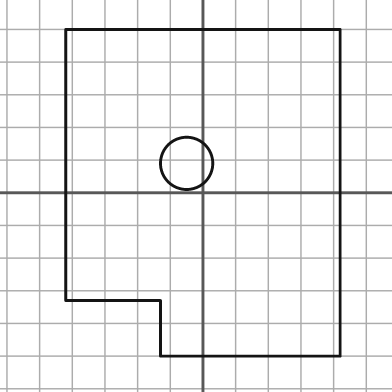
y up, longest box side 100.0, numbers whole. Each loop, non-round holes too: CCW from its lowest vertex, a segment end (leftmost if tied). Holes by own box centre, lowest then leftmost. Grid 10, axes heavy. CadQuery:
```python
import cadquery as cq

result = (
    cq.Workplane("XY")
    .moveTo(-13.0, -50.0)
    .lineTo(42.0, -50.0)
    .lineTo(42.0, 50.0)
    .lineTo(-42.0, 50.0)
    .lineTo(-42.0, -33.0)
    .lineTo(-13.0, -33.0)
    .close()
    .moveTo(-5.0, 9.0)
    .circle(8.0)
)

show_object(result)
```